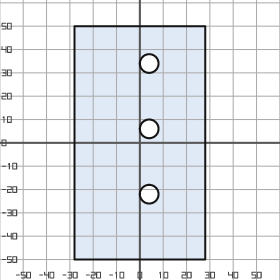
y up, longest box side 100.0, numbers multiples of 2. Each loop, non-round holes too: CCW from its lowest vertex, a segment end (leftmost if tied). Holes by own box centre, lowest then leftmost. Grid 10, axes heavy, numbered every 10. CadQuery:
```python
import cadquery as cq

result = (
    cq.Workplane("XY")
    .moveTo(-28.0, -50.0)
    .lineTo(28.0, -50.0)
    .lineTo(28.0, 50.0)
    .lineTo(-28.0, 50.0)
    .close()
    .moveTo(4.0, -22.0)
    .circle(4.0)
    .moveTo(4.0, 6.0)
    .circle(4.0)
    .moveTo(4.0, 34.0)
    .circle(4.0)
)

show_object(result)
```